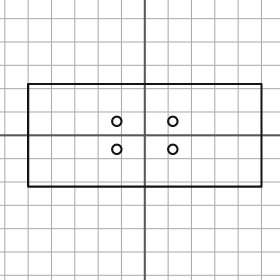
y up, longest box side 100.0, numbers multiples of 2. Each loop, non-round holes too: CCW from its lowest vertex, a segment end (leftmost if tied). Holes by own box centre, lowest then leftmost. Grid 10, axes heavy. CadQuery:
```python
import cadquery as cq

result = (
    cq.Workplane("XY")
    .moveTo(-50.0, -22.0)
    .lineTo(50.0, -22.0)
    .lineTo(50.0, 22.0)
    .lineTo(-50.0, 22.0)
    .close()
    .moveTo(-12.0, -6.0)
    .circle(2.0)
    .moveTo(12.0, -6.0)
    .circle(2.0)
    .moveTo(-12.0, 6.0)
    .circle(2.0)
    .moveTo(12.0, 6.0)
    .circle(2.0)
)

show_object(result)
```